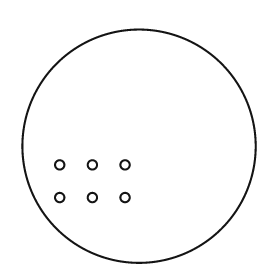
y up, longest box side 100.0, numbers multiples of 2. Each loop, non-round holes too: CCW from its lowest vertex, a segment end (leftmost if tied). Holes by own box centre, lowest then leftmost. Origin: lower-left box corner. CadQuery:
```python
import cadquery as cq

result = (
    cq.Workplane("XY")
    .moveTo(50.0, 50.0)
    .circle(50.0)
    .moveTo(16.0, 28.0)
    .circle(2.0)
    .moveTo(30.0, 28.0)
    .circle(2.0)
    .moveTo(44.0, 28.0)
    .circle(2.0)
    .moveTo(16.0, 42.0)
    .circle(2.0)
    .moveTo(30.0, 42.0)
    .circle(2.0)
    .moveTo(44.0, 42.0)
    .circle(2.0)
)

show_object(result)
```